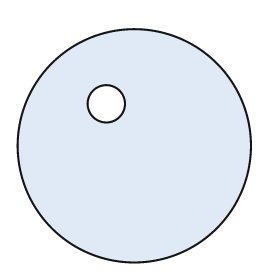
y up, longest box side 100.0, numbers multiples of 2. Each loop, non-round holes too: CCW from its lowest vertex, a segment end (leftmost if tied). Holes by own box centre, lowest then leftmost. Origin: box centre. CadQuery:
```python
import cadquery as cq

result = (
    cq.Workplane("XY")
    .moveTo(0.0, 0.0)
    .circle(50.0)
    .moveTo(-12.0, 18.0)
    .circle(8.0)
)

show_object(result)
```